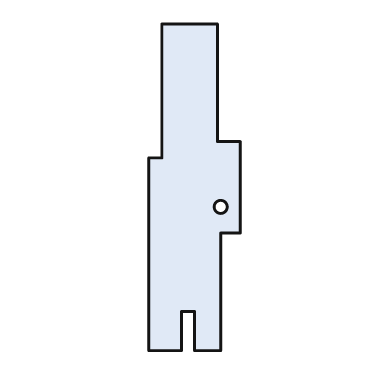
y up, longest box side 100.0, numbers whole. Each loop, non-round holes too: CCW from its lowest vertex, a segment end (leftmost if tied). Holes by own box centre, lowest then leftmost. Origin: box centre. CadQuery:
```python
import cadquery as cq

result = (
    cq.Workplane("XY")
    .moveTo(-14.0, -50.0)
    .lineTo(-4.0, -50.0)
    .lineTo(-4.0, -38.0)
    .lineTo(0.0, -38.0)
    .lineTo(0.0, -50.0)
    .lineTo(8.0, -50.0)
    .lineTo(8.0, -14.0)
    .lineTo(14.0, -14.0)
    .lineTo(14.0, 14.0)
    .lineTo(7.0, 14.0)
    .lineTo(7.0, 50.0)
    .lineTo(-10.0, 50.0)
    .lineTo(-10.0, 9.0)
    .lineTo(-14.0, 9.0)
    .close()
    .moveTo(8.0, -6.0)
    .circle(2.0)
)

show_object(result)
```